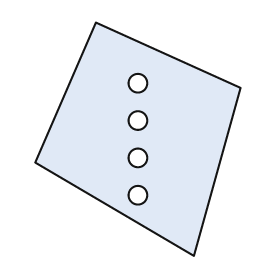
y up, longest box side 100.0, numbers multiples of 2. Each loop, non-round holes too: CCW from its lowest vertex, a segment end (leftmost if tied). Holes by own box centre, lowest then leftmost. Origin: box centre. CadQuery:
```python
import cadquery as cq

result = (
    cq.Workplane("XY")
    .moveTo(24.0, -50.0)
    .lineTo(44.0, 22.0)
    .lineTo(-18.0, 50.0)
    .lineTo(-44.0, -10.0)
    .close()
    .moveTo(0.0, -24.0)
    .circle(4.0)
    .moveTo(0.0, -8.0)
    .circle(4.0)
    .moveTo(0.0, 8.0)
    .circle(4.0)
    .moveTo(0.0, 24.0)
    .circle(4.0)
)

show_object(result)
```